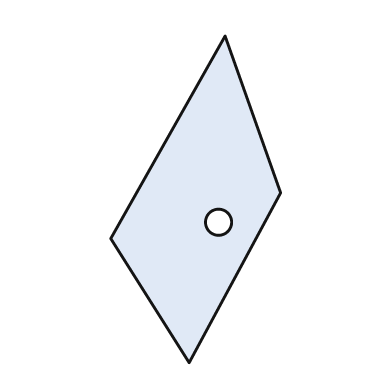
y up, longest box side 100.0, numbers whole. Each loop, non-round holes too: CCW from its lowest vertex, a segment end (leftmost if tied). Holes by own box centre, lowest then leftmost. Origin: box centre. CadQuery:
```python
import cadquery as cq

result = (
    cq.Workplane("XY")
    .moveTo(-2.0, -50.0)
    .lineTo(26.0, 2.0)
    .lineTo(9.0, 50.0)
    .lineTo(-26.0, -12.0)
    .close()
    .moveTo(7.0, -7.0)
    .circle(4.0)
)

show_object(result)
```